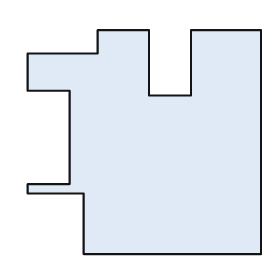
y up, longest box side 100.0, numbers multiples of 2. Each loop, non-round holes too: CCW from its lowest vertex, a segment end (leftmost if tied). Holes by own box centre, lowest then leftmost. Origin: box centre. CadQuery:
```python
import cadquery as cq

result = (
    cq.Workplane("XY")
    .moveTo(-26.0, -48.0)
    .lineTo(50.0, -48.0)
    .lineTo(50.0, 48.0)
    .lineTo(20.0, 48.0)
    .lineTo(20.0, 20.0)
    .lineTo(2.0, 20.0)
    .lineTo(2.0, 48.0)
    .lineTo(-20.0, 48.0)
    .lineTo(-20.0, 38.0)
    .lineTo(-50.0, 38.0)
    .lineTo(-50.0, 22.0)
    .lineTo(-32.0, 22.0)
    .lineTo(-32.0, -18.0)
    .lineTo(-50.0, -18.0)
    .lineTo(-50.0, -22.0)
    .lineTo(-26.0, -22.0)
    .close()
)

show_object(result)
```